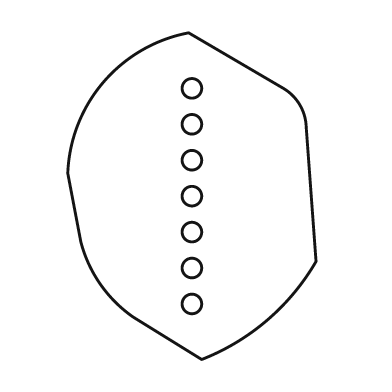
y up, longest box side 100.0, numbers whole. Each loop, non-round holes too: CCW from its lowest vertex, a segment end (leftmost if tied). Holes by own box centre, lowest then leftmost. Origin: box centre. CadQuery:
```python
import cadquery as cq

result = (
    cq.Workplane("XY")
    .moveTo(3.0, -50.0)
    .threePointArc((23.0, -38.0), (38.0, -20.0))
    .lineTo(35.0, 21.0)
    .threePointArc((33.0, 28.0), (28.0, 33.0))
    .lineTo(-1.0, 50.0)
    .threePointArc((-27.0, 35.0), (-38.0, 7.0))
    .lineTo(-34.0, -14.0)
    .threePointArc((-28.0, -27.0), (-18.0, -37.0))
    .close()
    .moveTo(0.0, -33.0)
    .circle(3.0)
    .moveTo(0.0, -22.0)
    .circle(3.0)
    .moveTo(0.0, -11.0)
    .circle(3.0)
    .moveTo(0.0, 0.0)
    .circle(3.0)
    .moveTo(0.0, 11.0)
    .circle(3.0)
    .moveTo(0.0, 22.0)
    .circle(3.0)
    .moveTo(0.0, 33.0)
    .circle(3.0)
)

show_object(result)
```